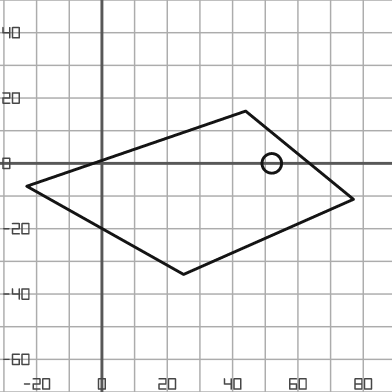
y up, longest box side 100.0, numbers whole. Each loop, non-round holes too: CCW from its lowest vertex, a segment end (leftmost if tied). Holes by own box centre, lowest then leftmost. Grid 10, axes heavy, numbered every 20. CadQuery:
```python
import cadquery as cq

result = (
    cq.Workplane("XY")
    .moveTo(25.0, -34.0)
    .lineTo(77.0, -11.0)
    .lineTo(44.0, 16.0)
    .lineTo(-23.0, -7.0)
    .close()
    .moveTo(52.0, 0.0)
    .circle(3.0)
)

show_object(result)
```